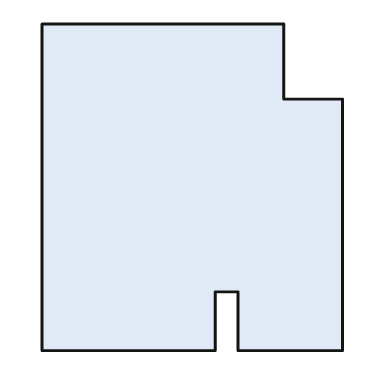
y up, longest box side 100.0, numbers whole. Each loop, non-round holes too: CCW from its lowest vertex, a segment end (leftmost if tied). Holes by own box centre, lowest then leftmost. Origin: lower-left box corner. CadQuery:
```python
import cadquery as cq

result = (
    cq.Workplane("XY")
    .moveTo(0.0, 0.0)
    .lineTo(53.0, 0.0)
    .lineTo(53.0, 18.0)
    .lineTo(60.0, 18.0)
    .lineTo(60.0, 0.0)
    .lineTo(92.0, 0.0)
    .lineTo(92.0, 77.0)
    .lineTo(74.0, 77.0)
    .lineTo(74.0, 100.0)
    .lineTo(0.0, 100.0)
    .close()
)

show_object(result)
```